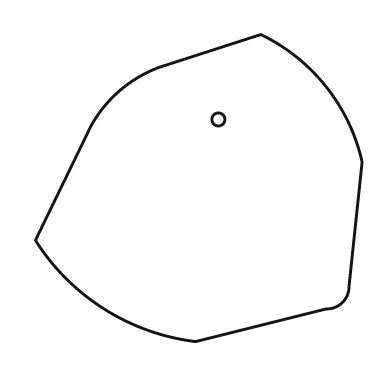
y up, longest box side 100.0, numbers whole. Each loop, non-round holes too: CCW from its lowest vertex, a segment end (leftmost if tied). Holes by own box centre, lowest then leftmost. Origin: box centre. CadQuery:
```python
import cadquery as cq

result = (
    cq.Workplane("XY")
    .moveTo(-1.0, -47.0)
    .lineTo(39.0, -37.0)
    .threePointArc((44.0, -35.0), (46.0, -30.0))
    .lineTo(50.0, 8.0)
    .threePointArc((39.0, 31.0), (19.0, 47.0))
    .lineTo(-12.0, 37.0)
    .threePointArc((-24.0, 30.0), (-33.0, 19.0))
    .lineTo(-50.0, -16.0)
    .threePointArc((-29.0, -37.0), (-1.0, -47.0))
    .close()
    .moveTo(6.0, 21.0)
    .circle(2.0)
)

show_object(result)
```